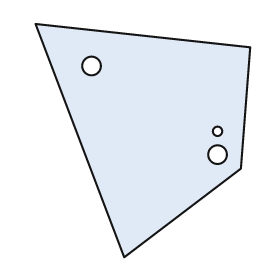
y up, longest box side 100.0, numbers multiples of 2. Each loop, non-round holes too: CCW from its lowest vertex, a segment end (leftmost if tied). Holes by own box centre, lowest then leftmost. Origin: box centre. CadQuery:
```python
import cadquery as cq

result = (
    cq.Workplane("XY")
    .moveTo(-8.0, -50.0)
    .lineTo(42.0, -12.0)
    .lineTo(46.0, 40.0)
    .lineTo(-46.0, 50.0)
    .close()
    .moveTo(32.0, -6.0)
    .circle(4.0)
    .moveTo(32.0, 4.0)
    .circle(2.0)
    .moveTo(-22.0, 32.0)
    .circle(4.0)
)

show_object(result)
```